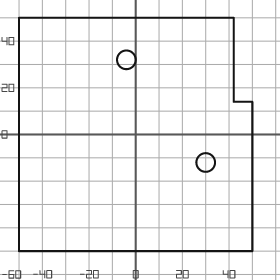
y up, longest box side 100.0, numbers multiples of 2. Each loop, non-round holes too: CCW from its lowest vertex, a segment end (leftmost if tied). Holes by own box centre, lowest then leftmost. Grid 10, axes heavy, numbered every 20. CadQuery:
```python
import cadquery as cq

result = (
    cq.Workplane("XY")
    .moveTo(-50.0, -50.0)
    .lineTo(50.0, -50.0)
    .lineTo(50.0, 14.0)
    .lineTo(42.0, 14.0)
    .lineTo(42.0, 50.0)
    .lineTo(-50.0, 50.0)
    .close()
    .moveTo(30.0, -12.0)
    .circle(4.0)
    .moveTo(-4.0, 32.0)
    .circle(4.0)
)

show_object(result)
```